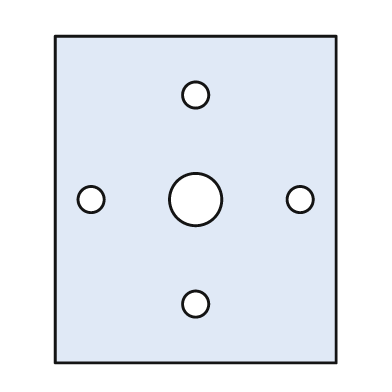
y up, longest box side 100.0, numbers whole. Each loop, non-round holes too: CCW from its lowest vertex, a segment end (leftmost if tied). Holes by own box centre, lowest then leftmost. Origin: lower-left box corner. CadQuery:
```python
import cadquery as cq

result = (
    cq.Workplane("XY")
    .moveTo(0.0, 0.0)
    .lineTo(86.0, 0.0)
    .lineTo(86.0, 100.0)
    .lineTo(0.0, 100.0)
    .close()
    .moveTo(43.0, 18.0)
    .circle(4.0)
    .moveTo(11.0, 50.0)
    .circle(4.0)
    .moveTo(43.0, 50.0)
    .circle(8.0)
    .moveTo(75.0, 50.0)
    .circle(4.0)
    .moveTo(43.0, 82.0)
    .circle(4.0)
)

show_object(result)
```